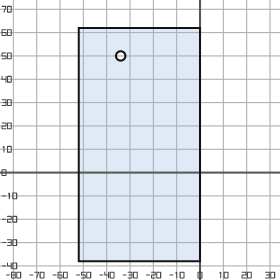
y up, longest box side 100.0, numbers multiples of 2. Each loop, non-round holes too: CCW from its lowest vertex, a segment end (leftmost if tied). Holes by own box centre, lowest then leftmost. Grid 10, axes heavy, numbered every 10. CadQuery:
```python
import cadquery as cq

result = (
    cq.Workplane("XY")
    .moveTo(-52.0, -38.0)
    .lineTo(0.0, -38.0)
    .lineTo(0.0, 62.0)
    .lineTo(-52.0, 62.0)
    .close()
    .moveTo(-34.0, 50.0)
    .circle(2.0)
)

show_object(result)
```